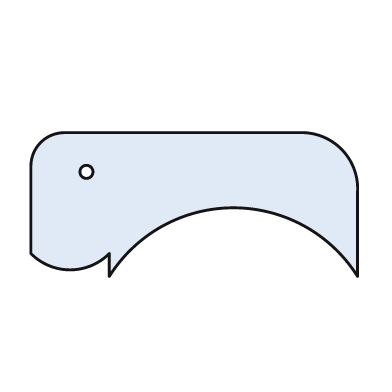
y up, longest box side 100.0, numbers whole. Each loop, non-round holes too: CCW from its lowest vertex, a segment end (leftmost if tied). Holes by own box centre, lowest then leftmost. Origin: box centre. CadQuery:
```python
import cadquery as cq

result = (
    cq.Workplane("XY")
    .moveTo(-26.0, -22.0)
    .threePointArc((12.0, -1.0), (50.0, -22.0))
    .lineTo(50.0, 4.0)
    .threePointArc((45.0, 17.0), (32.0, 22.0))
    .lineTo(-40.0, 22.0)
    .threePointArc((-47.0, 19.0), (-50.0, 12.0))
    .lineTo(-50.0, -15.0)
    .threePointArc((-38.0, -20.0), (-26.0, -15.0))
    .close()
    .moveTo(-33.0, 10.0)
    .circle(2.0)
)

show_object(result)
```